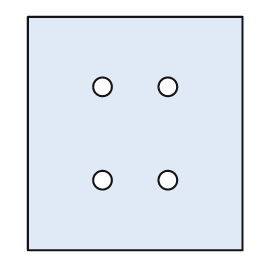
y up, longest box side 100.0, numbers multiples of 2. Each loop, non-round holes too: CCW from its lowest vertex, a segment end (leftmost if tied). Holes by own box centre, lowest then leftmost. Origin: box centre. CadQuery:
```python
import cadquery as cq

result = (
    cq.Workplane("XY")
    .moveTo(-46.0, -50.0)
    .lineTo(46.0, -50.0)
    .lineTo(46.0, 50.0)
    .lineTo(-46.0, 50.0)
    .close()
    .moveTo(-14.0, -20.0)
    .circle(4.0)
    .moveTo(14.0, -20.0)
    .circle(4.0)
    .moveTo(-14.0, 20.0)
    .circle(4.0)
    .moveTo(14.0, 20.0)
    .circle(4.0)
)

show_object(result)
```